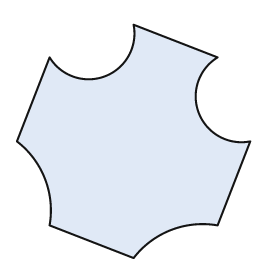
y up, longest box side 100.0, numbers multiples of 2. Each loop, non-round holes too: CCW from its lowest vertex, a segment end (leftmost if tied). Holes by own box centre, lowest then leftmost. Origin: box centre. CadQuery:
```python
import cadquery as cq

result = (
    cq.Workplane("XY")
    .moveTo(0.0, -50.0)
    .threePointArc((16.0, -38.0), (36.0, -36.0))
    .lineTo(50.0, 0.0)
    .threePointArc((28.0, 12.0), (36.0, 36.0))
    .lineTo(0.0, 50.0)
    .threePointArc((-12.0, 28.0), (-36.0, 36.0))
    .lineTo(-50.0, 0.0)
    .threePointArc((-38.0, -16.0), (-36.0, -36.0))
    .close()
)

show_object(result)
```